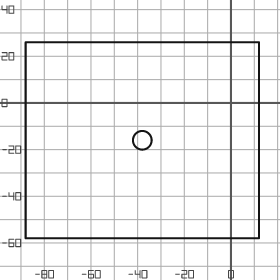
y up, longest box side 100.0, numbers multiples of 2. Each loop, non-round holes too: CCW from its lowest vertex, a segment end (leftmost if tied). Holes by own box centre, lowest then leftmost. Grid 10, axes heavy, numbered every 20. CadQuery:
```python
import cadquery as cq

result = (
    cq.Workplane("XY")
    .moveTo(-88.0, -58.0)
    .lineTo(12.0, -58.0)
    .lineTo(12.0, 26.0)
    .lineTo(-88.0, 26.0)
    .close()
    .moveTo(-38.0, -16.0)
    .circle(4.0)
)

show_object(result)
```